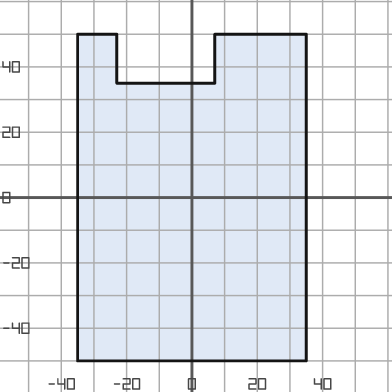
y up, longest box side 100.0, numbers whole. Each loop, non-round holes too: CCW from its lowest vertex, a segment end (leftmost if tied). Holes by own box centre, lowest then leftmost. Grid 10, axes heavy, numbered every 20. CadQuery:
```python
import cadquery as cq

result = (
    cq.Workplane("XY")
    .moveTo(-35.0, -50.0)
    .lineTo(35.0, -50.0)
    .lineTo(35.0, 50.0)
    .lineTo(7.0, 50.0)
    .lineTo(7.0, 35.0)
    .lineTo(-23.0, 35.0)
    .lineTo(-23.0, 50.0)
    .lineTo(-35.0, 50.0)
    .close()
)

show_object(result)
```